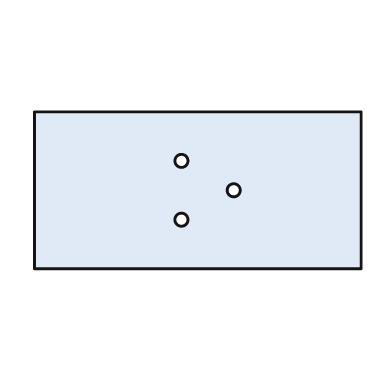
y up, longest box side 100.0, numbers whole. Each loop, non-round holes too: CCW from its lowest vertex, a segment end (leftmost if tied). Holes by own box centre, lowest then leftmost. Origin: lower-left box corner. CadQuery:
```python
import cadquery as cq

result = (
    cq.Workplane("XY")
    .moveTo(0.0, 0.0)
    .lineTo(100.0, 0.0)
    .lineTo(100.0, 48.0)
    .lineTo(0.0, 48.0)
    .close()
    .moveTo(45.0, 15.0)
    .circle(2.0)
    .moveTo(61.0, 24.0)
    .circle(2.0)
    .moveTo(45.0, 33.0)
    .circle(2.0)
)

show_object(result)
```